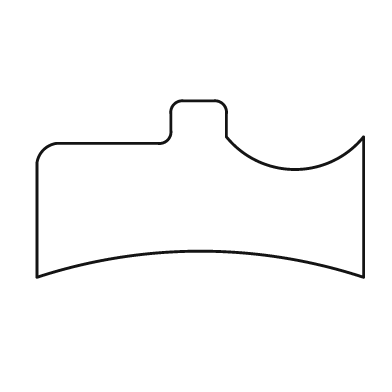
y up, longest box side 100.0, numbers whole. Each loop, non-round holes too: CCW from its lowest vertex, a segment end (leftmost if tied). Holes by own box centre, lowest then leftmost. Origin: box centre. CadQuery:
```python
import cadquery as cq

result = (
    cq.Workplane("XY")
    .moveTo(-50.0, -27.0)
    .threePointArc((0.0, -19.0), (50.0, -27.0))
    .lineTo(50.0, 16.0)
    .threePointArc((29.0, 6.0), (8.0, 16.0))
    .lineTo(8.0, 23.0)
    .threePointArc((7.0, 26.0), (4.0, 27.0))
    .lineTo(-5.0, 27.0)
    .threePointArc((-8.0, 26.0), (-9.0, 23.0))
    .lineTo(-9.0, 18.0)
    .threePointArc((-10.0, 15.0), (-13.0, 14.0))
    .lineTo(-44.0, 14.0)
    .threePointArc((-48.0, 12.0), (-50.0, 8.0))
    .close()
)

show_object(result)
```